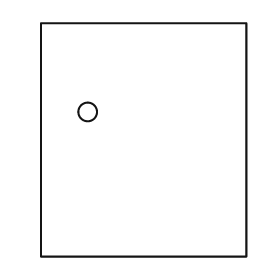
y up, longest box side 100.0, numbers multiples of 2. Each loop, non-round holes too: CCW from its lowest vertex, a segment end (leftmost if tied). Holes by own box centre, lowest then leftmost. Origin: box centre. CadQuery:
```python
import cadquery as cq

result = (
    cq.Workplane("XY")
    .moveTo(-44.0, -50.0)
    .lineTo(44.0, -50.0)
    .lineTo(44.0, 50.0)
    .lineTo(-44.0, 50.0)
    .close()
    .moveTo(-24.0, 12.0)
    .circle(4.0)
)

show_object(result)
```